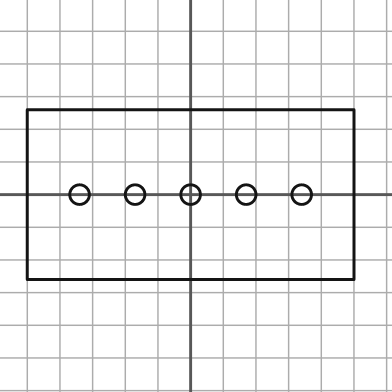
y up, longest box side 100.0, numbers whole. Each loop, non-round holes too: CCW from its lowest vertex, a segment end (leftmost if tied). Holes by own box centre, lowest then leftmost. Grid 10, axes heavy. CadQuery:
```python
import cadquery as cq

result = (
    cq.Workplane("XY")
    .moveTo(-50.0, -26.0)
    .lineTo(50.0, -26.0)
    .lineTo(50.0, 26.0)
    .lineTo(-50.0, 26.0)
    .close()
    .moveTo(-34.0, 0.0)
    .circle(3.0)
    .moveTo(-17.0, 0.0)
    .circle(3.0)
    .moveTo(0.0, 0.0)
    .circle(3.0)
    .moveTo(17.0, 0.0)
    .circle(3.0)
    .moveTo(34.0, 0.0)
    .circle(3.0)
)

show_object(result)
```